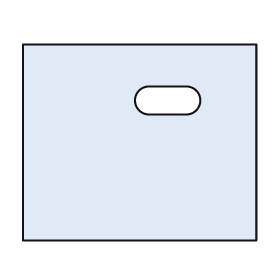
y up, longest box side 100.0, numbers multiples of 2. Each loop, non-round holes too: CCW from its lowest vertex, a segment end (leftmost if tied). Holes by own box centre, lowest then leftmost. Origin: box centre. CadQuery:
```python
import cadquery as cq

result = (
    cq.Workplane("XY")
    .moveTo(-50.0, -42.0)
    .lineTo(50.0, -42.0)
    .lineTo(50.0, 42.0)
    .lineTo(-50.0, 42.0)
    .close()
    .moveTo(4.0, 12.0)
    .lineTo(20.0, 12.0)
    .threePointArc((26.0, 18.0), (20.0, 24.0))
    .lineTo(4.0, 24.0)
    .threePointArc((-2.0, 18.0), (4.0, 12.0))
    .close()
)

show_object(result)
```